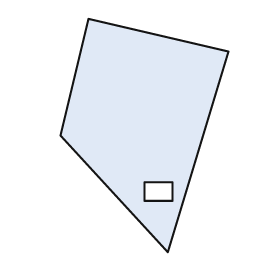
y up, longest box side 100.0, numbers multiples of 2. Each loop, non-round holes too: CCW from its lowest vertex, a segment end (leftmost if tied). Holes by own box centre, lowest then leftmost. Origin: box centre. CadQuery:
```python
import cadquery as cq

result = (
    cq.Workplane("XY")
    .moveTo(10.0, -50.0)
    .lineTo(36.0, 36.0)
    .lineTo(-24.0, 50.0)
    .lineTo(-36.0, 0.0)
    .close()
    .moveTo(0.0, -28.0)
    .lineTo(12.0, -28.0)
    .lineTo(12.0, -20.0)
    .lineTo(0.0, -20.0)
    .close()
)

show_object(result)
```